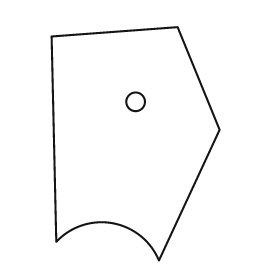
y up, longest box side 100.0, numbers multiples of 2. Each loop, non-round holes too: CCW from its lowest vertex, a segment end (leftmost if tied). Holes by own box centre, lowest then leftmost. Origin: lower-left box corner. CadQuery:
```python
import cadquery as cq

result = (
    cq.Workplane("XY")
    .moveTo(46.0, 0.0)
    .lineTo(72.0, 56.0)
    .lineTo(54.0, 100.0)
    .lineTo(0.0, 96.0)
    .lineTo(2.0, 8.0)
    .threePointArc((26.0, 16.0), (46.0, 0.0))
    .close()
    .moveTo(36.0, 68.0)
    .circle(4.0)
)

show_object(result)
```